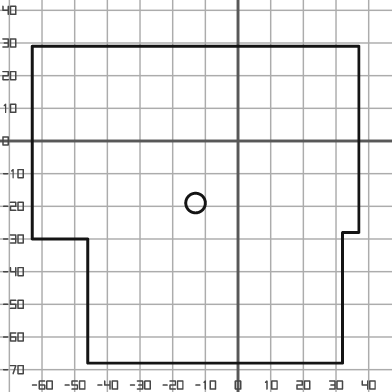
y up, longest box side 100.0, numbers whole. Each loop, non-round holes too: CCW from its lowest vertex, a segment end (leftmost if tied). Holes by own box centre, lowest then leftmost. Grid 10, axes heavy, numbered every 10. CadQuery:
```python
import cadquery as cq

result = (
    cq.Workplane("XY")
    .moveTo(-46.0, -68.0)
    .lineTo(32.0, -68.0)
    .lineTo(32.0, -28.0)
    .lineTo(37.0, -28.0)
    .lineTo(37.0, 29.0)
    .lineTo(-63.0, 29.0)
    .lineTo(-63.0, -30.0)
    .lineTo(-46.0, -30.0)
    .close()
    .moveTo(-13.0, -19.0)
    .circle(3.0)
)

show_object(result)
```